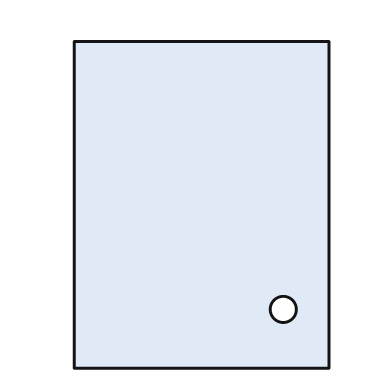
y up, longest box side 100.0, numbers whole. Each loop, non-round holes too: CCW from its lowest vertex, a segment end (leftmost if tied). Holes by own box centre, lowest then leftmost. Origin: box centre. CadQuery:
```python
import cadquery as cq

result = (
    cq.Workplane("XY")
    .moveTo(-39.0, -50.0)
    .lineTo(39.0, -50.0)
    .lineTo(39.0, 50.0)
    .lineTo(-39.0, 50.0)
    .close()
    .moveTo(25.0, -32.0)
    .circle(4.0)
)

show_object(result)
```